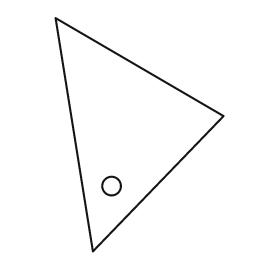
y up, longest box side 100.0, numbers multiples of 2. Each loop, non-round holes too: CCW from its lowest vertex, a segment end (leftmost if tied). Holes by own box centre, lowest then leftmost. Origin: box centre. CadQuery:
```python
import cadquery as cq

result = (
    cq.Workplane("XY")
    .moveTo(-20.0, -50.0)
    .lineTo(36.0, 8.0)
    .lineTo(-36.0, 50.0)
    .close()
    .moveTo(-12.0, -22.0)
    .circle(4.0)
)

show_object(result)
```